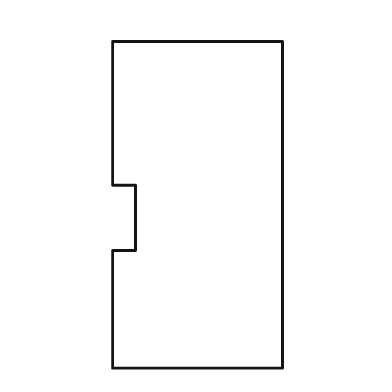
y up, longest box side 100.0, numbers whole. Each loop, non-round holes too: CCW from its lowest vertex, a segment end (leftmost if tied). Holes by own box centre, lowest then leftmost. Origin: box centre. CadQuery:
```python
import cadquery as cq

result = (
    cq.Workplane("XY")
    .moveTo(-26.0, -50.0)
    .lineTo(26.0, -50.0)
    .lineTo(26.0, 50.0)
    .lineTo(-26.0, 50.0)
    .lineTo(-26.0, 6.0)
    .lineTo(-19.0, 6.0)
    .lineTo(-19.0, -14.0)
    .lineTo(-26.0, -14.0)
    .close()
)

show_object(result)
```